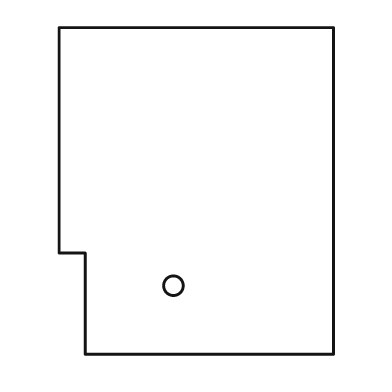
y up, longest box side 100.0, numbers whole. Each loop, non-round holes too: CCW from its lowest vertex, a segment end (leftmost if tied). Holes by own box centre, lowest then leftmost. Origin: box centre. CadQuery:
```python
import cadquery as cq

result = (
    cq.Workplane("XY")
    .moveTo(-34.0, -50.0)
    .lineTo(42.0, -50.0)
    .lineTo(42.0, 50.0)
    .lineTo(-42.0, 50.0)
    .lineTo(-42.0, -19.0)
    .lineTo(-34.0, -19.0)
    .close()
    .moveTo(-7.0, -29.0)
    .circle(3.0)
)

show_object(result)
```